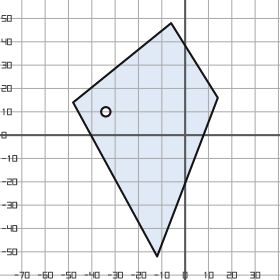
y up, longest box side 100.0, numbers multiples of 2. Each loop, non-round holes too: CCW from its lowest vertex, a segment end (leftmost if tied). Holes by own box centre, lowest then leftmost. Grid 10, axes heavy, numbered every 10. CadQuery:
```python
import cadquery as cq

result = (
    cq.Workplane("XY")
    .moveTo(-12.0, -52.0)
    .lineTo(14.0, 16.0)
    .lineTo(-6.0, 48.0)
    .lineTo(-48.0, 14.0)
    .close()
    .moveTo(-34.0, 10.0)
    .circle(2.0)
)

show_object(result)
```